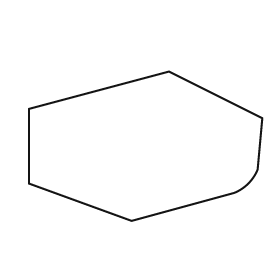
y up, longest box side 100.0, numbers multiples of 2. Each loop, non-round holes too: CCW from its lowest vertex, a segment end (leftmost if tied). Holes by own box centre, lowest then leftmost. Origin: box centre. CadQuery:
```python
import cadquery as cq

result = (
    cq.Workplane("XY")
    .moveTo(-6.0, -32.0)
    .lineTo(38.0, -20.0)
    .threePointArc((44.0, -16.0), (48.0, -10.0))
    .lineTo(50.0, 12.0)
    .lineTo(10.0, 32.0)
    .lineTo(-50.0, 16.0)
    .lineTo(-50.0, -16.0)
    .close()
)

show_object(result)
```